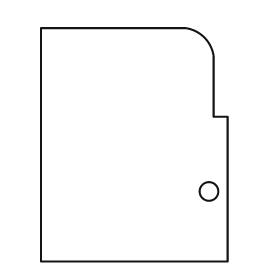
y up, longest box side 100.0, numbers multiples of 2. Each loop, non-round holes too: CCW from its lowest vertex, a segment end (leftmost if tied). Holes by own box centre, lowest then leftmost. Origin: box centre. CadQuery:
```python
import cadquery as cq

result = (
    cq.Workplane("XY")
    .moveTo(-40.0, -50.0)
    .lineTo(40.0, -50.0)
    .lineTo(40.0, 12.0)
    .lineTo(34.0, 12.0)
    .lineTo(34.0, 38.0)
    .threePointArc((30.0, 46.0), (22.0, 50.0))
    .lineTo(-40.0, 50.0)
    .close()
    .moveTo(32.0, -20.0)
    .circle(4.0)
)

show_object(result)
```